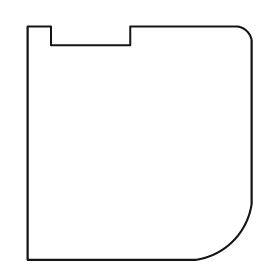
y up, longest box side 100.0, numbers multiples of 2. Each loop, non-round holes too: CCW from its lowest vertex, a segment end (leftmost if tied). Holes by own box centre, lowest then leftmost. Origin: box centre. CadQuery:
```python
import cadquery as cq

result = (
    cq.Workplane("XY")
    .moveTo(-48.0, -50.0)
    .lineTo(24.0, -50.0)
    .threePointArc((40.0, -42.0), (48.0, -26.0))
    .lineTo(48.0, 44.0)
    .threePointArc((46.0, 48.0), (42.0, 50.0))
    .lineTo(-4.0, 50.0)
    .lineTo(-4.0, 42.0)
    .lineTo(-38.0, 42.0)
    .lineTo(-38.0, 50.0)
    .lineTo(-48.0, 50.0)
    .close()
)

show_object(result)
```